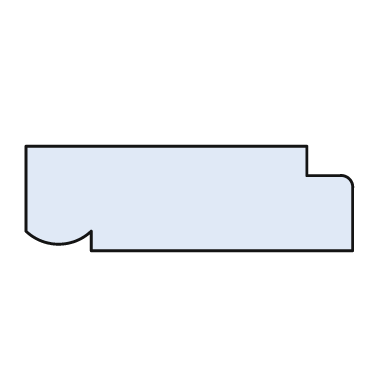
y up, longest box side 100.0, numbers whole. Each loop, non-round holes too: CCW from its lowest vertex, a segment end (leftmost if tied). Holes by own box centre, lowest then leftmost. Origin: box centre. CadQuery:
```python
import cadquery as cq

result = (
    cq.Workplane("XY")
    .moveTo(-30.0, -16.0)
    .lineTo(50.0, -16.0)
    .lineTo(50.0, 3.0)
    .threePointArc((49.0, 6.0), (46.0, 7.0))
    .lineTo(36.0, 7.0)
    .lineTo(36.0, 16.0)
    .lineTo(-50.0, 16.0)
    .lineTo(-50.0, -10.0)
    .threePointArc((-40.0, -14.0), (-30.0, -10.0))
    .close()
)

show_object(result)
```